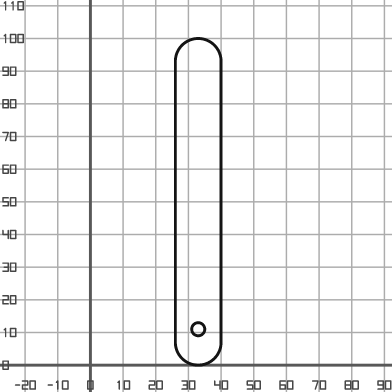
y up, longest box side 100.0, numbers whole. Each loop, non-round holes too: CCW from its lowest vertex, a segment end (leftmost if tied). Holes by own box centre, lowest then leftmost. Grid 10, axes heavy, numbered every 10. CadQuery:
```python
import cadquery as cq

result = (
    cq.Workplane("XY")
    .moveTo(26.0, 7.0)
    .threePointArc((33.0, 0.0), (40.0, 7.0))
    .lineTo(40.0, 93.0)
    .threePointArc((33.0, 100.0), (26.0, 93.0))
    .close()
    .moveTo(33.0, 11.0)
    .circle(2.0)
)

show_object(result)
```